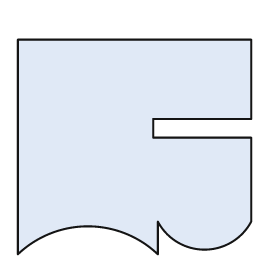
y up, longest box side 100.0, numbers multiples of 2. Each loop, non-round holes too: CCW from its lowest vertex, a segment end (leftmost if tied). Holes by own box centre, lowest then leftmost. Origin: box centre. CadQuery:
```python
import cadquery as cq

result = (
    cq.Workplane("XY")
    .moveTo(-50.0, -46.0)
    .threePointArc((-20.0, -34.0), (10.0, -46.0))
    .lineTo(10.0, -32.0)
    .threePointArc((30.0, -44.0), (50.0, -32.0))
    .lineTo(50.0, 4.0)
    .lineTo(8.0, 4.0)
    .lineTo(8.0, 12.0)
    .lineTo(50.0, 12.0)
    .lineTo(50.0, 46.0)
    .lineTo(-50.0, 46.0)
    .close()
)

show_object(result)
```